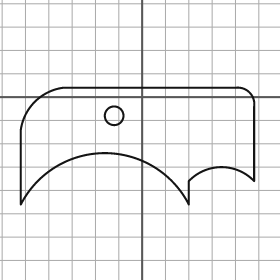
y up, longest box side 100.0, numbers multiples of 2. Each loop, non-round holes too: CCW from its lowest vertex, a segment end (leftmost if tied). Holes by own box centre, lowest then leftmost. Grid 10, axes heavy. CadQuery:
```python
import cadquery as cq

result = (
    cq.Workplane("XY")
    .moveTo(-52.0, -46.0)
    .threePointArc((-16.0, -24.0), (20.0, -46.0))
    .lineTo(20.0, -36.0)
    .threePointArc((34.0, -30.0), (48.0, -36.0))
    .lineTo(48.0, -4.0)
    .threePointArc((46.0, 2.0), (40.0, 4.0))
    .lineTo(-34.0, 4.0)
    .threePointArc((-46.0, -2.0), (-52.0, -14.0))
    .close()
    .moveTo(-12.0, -8.0)
    .circle(4.0)
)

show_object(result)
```